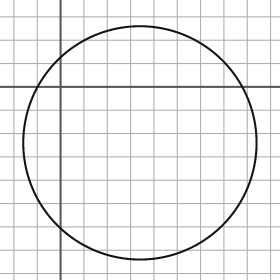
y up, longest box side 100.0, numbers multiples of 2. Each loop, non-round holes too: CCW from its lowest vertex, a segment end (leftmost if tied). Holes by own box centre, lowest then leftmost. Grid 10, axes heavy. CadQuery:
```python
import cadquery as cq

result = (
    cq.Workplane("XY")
    .moveTo(34.0, -24.0)
    .circle(50.0)
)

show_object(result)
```